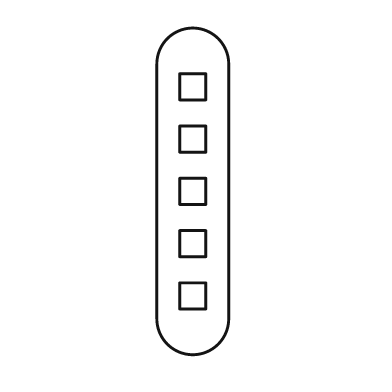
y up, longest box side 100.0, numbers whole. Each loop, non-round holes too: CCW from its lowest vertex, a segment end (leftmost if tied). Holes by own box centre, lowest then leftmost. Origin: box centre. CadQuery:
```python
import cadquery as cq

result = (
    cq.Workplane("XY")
    .moveTo(-11.0, -39.0)
    .threePointArc((0.0, -50.0), (11.0, -39.0))
    .lineTo(11.0, 39.0)
    .threePointArc((0.0, 50.0), (-11.0, 39.0))
    .close()
    .moveTo(-4.0, -36.0)
    .lineTo(4.0, -36.0)
    .lineTo(4.0, -28.0)
    .lineTo(-4.0, -28.0)
    .close()
    .moveTo(-4.0, -20.0)
    .lineTo(4.0, -20.0)
    .lineTo(4.0, -12.0)
    .lineTo(-4.0, -12.0)
    .close()
    .moveTo(-4.0, -4.0)
    .lineTo(4.0, -4.0)
    .lineTo(4.0, 4.0)
    .lineTo(-4.0, 4.0)
    .close()
    .moveTo(-4.0, 12.0)
    .lineTo(4.0, 12.0)
    .lineTo(4.0, 20.0)
    .lineTo(-4.0, 20.0)
    .close()
    .moveTo(-4.0, 28.0)
    .lineTo(4.0, 28.0)
    .lineTo(4.0, 36.0)
    .lineTo(-4.0, 36.0)
    .close()
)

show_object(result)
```